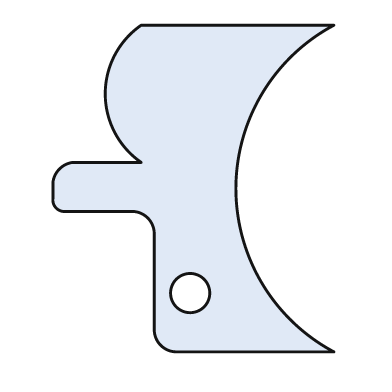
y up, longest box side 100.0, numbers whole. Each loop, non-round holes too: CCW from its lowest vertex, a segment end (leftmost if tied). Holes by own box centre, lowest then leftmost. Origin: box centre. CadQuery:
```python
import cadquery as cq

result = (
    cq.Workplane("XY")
    .moveTo(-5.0, -50.0)
    .lineTo(43.0, -50.0)
    .threePointArc((13.0, 0.0), (43.0, 50.0))
    .lineTo(-16.0, 50.0)
    .threePointArc((-27.0, 29.0), (-16.0, 8.0))
    .lineTo(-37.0, 8.0)
    .threePointArc((-41.0, 6.0), (-43.0, 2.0))
    .lineTo(-43.0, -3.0)
    .threePointArc((-42.0, -6.0), (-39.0, -7.0))
    .lineTo(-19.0, -7.0)
    .threePointArc((-14.0, -9.0), (-12.0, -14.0))
    .lineTo(-12.0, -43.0)
    .threePointArc((-10.0, -48.0), (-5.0, -50.0))
    .close()
    .moveTo(-1.0, -32.0)
    .circle(6.0)
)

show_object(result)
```